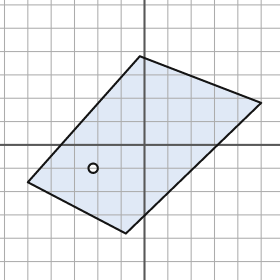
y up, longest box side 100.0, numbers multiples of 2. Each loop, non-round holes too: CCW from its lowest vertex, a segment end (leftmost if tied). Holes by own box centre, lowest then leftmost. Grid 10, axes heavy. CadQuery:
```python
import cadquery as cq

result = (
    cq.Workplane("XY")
    .moveTo(-8.0, -38.0)
    .lineTo(50.0, 18.0)
    .lineTo(-2.0, 38.0)
    .lineTo(-50.0, -16.0)
    .close()
    .moveTo(-22.0, -10.0)
    .circle(2.0)
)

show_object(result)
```